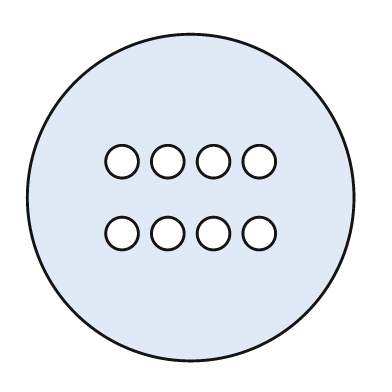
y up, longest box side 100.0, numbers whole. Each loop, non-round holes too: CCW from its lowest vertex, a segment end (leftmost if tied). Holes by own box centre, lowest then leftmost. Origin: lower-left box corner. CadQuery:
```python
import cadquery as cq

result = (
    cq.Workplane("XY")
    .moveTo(50.0, 50.0)
    .circle(50.0)
    .moveTo(29.0, 39.0)
    .circle(5.0)
    .moveTo(43.0, 39.0)
    .circle(5.0)
    .moveTo(57.0, 39.0)
    .circle(5.0)
    .moveTo(71.0, 39.0)
    .circle(5.0)
    .moveTo(29.0, 61.0)
    .circle(5.0)
    .moveTo(43.0, 61.0)
    .circle(5.0)
    .moveTo(57.0, 61.0)
    .circle(5.0)
    .moveTo(71.0, 61.0)
    .circle(5.0)
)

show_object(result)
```